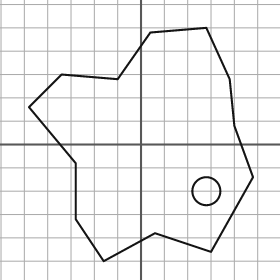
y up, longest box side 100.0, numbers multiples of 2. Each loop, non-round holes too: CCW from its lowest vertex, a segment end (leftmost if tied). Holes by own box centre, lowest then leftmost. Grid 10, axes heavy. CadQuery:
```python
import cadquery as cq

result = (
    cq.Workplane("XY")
    .moveTo(-16.0, -50.0)
    .lineTo(6.0, -38.0)
    .lineTo(30.0, -46.0)
    .lineTo(48.0, -14.0)
    .lineTo(40.0, 8.0)
    .lineTo(38.0, 28.0)
    .lineTo(28.0, 50.0)
    .lineTo(4.0, 48.0)
    .lineTo(-10.0, 28.0)
    .lineTo(-34.0, 30.0)
    .lineTo(-48.0, 16.0)
    .lineTo(-28.0, -8.0)
    .lineTo(-28.0, -32.0)
    .close()
    .moveTo(28.0, -20.0)
    .circle(6.0)
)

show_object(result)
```